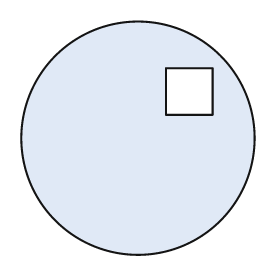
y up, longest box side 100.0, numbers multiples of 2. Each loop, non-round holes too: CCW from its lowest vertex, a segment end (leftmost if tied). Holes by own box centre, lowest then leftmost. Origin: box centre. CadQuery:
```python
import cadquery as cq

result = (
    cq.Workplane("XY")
    .moveTo(0.0, 0.0)
    .circle(50.0)
    .moveTo(12.0, 10.0)
    .lineTo(32.0, 10.0)
    .lineTo(32.0, 30.0)
    .lineTo(12.0, 30.0)
    .close()
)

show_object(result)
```